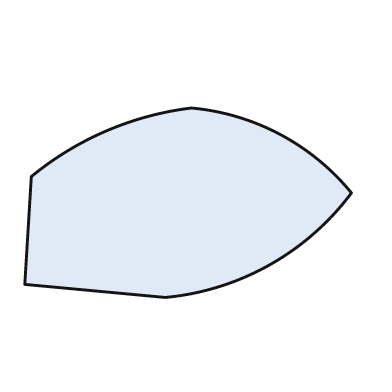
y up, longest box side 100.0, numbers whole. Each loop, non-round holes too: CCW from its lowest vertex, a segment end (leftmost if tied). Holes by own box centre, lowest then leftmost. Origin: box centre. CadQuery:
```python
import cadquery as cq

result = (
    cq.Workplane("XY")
    .moveTo(-7.0, -29.0)
    .threePointArc((25.0, -19.0), (50.0, 3.0))
    .threePointArc((28.0, 21.0), (1.0, 29.0))
    .threePointArc((-25.0, 22.0), (-48.0, 8.0))
    .lineTo(-50.0, -25.0)
    .close()
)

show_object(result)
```